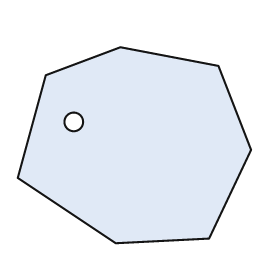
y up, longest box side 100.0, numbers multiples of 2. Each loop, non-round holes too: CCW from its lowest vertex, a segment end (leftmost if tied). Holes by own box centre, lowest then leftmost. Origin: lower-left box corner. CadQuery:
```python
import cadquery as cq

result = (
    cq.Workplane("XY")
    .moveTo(42.0, 0.0)
    .lineTo(82.0, 2.0)
    .lineTo(100.0, 40.0)
    .lineTo(86.0, 76.0)
    .lineTo(44.0, 84.0)
    .lineTo(12.0, 72.0)
    .lineTo(0.0, 28.0)
    .close()
    .moveTo(24.0, 52.0)
    .circle(4.0)
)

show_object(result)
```